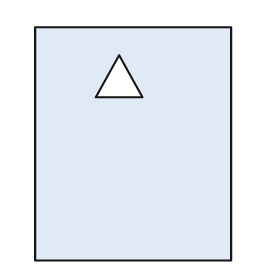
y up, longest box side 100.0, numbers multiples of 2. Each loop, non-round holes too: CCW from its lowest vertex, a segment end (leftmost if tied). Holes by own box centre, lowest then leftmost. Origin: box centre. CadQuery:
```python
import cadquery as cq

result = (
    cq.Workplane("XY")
    .moveTo(-42.0, -50.0)
    .lineTo(42.0, -50.0)
    .lineTo(42.0, 50.0)
    .lineTo(-42.0, 50.0)
    .close()
    .moveTo(-16.0, 20.0)
    .lineTo(4.0, 20.0)
    .lineTo(-6.0, 38.0)
    .close()
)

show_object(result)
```